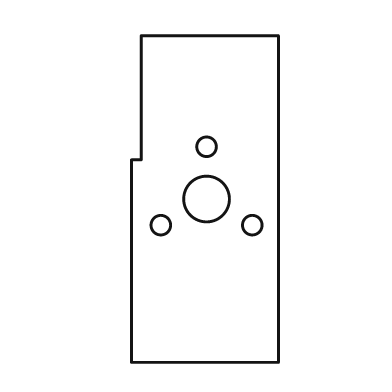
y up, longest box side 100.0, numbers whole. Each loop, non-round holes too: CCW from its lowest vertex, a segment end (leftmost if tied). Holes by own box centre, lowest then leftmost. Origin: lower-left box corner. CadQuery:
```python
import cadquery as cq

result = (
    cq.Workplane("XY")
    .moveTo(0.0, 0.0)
    .lineTo(45.0, 0.0)
    .lineTo(45.0, 100.0)
    .lineTo(3.0, 100.0)
    .lineTo(3.0, 62.0)
    .lineTo(0.0, 62.0)
    .close()
    .moveTo(9.0, 42.0)
    .circle(3.0)
    .moveTo(37.0, 42.0)
    .circle(3.0)
    .moveTo(23.0, 50.0)
    .circle(7.0)
    .moveTo(23.0, 66.0)
    .circle(3.0)
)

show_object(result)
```